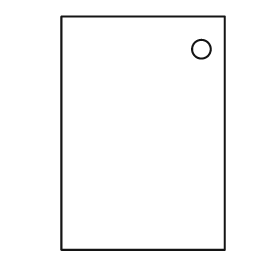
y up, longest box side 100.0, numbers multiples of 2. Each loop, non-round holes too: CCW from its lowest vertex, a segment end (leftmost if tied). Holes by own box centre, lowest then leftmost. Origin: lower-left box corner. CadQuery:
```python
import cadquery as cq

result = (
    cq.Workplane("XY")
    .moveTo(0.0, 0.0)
    .lineTo(70.0, 0.0)
    .lineTo(70.0, 100.0)
    .lineTo(0.0, 100.0)
    .close()
    .moveTo(60.0, 86.0)
    .circle(4.0)
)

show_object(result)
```